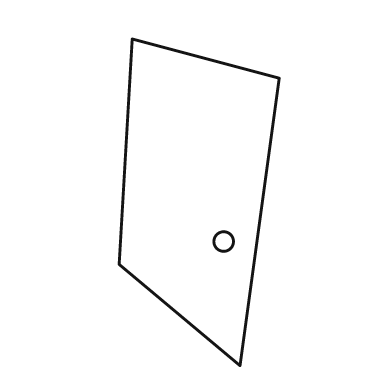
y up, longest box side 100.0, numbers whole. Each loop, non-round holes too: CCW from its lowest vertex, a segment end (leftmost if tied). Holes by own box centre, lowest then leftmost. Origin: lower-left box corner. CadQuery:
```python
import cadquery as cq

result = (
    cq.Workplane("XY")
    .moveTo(37.0, 0.0)
    .lineTo(49.0, 88.0)
    .lineTo(4.0, 100.0)
    .lineTo(0.0, 31.0)
    .close()
    .moveTo(32.0, 38.0)
    .circle(3.0)
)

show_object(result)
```